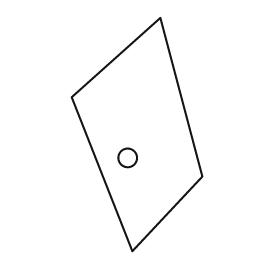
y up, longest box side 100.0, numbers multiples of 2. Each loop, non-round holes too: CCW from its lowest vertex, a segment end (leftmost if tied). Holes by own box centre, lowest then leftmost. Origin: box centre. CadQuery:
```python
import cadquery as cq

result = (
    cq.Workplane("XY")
    .moveTo(-2.0, -50.0)
    .lineTo(28.0, -18.0)
    .lineTo(10.0, 50.0)
    .lineTo(-28.0, 16.0)
    .close()
    .moveTo(-4.0, -10.0)
    .circle(4.0)
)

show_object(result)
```